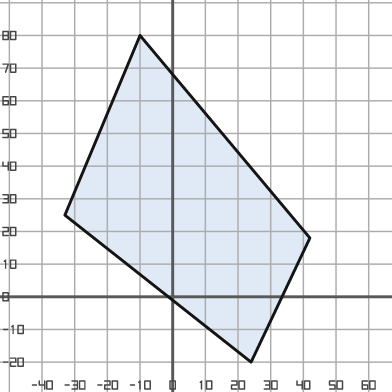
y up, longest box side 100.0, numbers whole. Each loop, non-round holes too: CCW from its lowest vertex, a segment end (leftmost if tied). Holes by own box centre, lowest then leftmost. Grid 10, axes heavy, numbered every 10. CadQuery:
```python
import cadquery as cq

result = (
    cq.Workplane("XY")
    .moveTo(24.0, -20.0)
    .lineTo(42.0, 18.0)
    .lineTo(-10.0, 80.0)
    .lineTo(-33.0, 25.0)
    .close()
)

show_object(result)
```